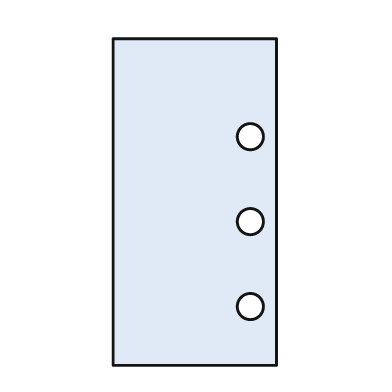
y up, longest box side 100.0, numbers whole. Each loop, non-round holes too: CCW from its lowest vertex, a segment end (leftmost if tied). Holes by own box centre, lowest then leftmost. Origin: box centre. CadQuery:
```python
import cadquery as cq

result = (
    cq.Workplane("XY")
    .moveTo(-25.0, -50.0)
    .lineTo(25.0, -50.0)
    .lineTo(25.0, 50.0)
    .lineTo(-25.0, 50.0)
    .close()
    .moveTo(17.0, -32.0)
    .circle(4.0)
    .moveTo(17.0, -6.0)
    .circle(4.0)
    .moveTo(17.0, 20.0)
    .circle(4.0)
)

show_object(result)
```